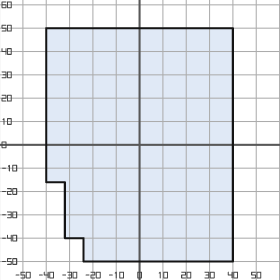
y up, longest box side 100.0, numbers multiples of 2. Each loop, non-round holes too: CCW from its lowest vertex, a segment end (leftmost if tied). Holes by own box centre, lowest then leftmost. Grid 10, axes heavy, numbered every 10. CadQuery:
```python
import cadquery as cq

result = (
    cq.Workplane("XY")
    .moveTo(-24.0, -50.0)
    .lineTo(40.0, -50.0)
    .lineTo(40.0, 50.0)
    .lineTo(-40.0, 50.0)
    .lineTo(-40.0, -16.0)
    .lineTo(-32.0, -16.0)
    .lineTo(-32.0, -40.0)
    .lineTo(-24.0, -40.0)
    .close()
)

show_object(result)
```